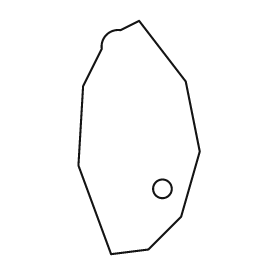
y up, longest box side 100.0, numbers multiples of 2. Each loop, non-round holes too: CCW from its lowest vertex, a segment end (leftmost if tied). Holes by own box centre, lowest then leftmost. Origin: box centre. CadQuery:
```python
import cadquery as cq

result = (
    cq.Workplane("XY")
    .moveTo(-12.0, -50.0)
    .lineTo(4.0, -48.0)
    .lineTo(18.0, -34.0)
    .lineTo(26.0, -6.0)
    .lineTo(20.0, 24.0)
    .lineTo(0.0, 50.0)
    .lineTo(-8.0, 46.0)
    .threePointArc((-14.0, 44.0), (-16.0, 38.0))
    .lineTo(-24.0, 22.0)
    .lineTo(-26.0, -12.0)
    .close()
    .moveTo(10.0, -22.0)
    .circle(4.0)
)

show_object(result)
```